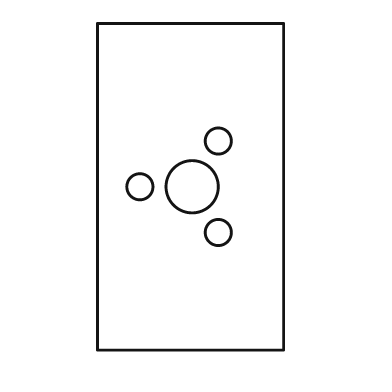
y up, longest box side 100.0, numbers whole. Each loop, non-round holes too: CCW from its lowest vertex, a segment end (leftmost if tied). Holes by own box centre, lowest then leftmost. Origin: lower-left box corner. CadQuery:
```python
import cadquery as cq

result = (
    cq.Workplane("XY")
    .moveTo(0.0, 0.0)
    .lineTo(57.0, 0.0)
    .lineTo(57.0, 100.0)
    .lineTo(0.0, 100.0)
    .close()
    .moveTo(37.0, 36.0)
    .circle(4.0)
    .moveTo(13.0, 50.0)
    .circle(4.0)
    .moveTo(29.0, 50.0)
    .circle(8.0)
    .moveTo(37.0, 64.0)
    .circle(4.0)
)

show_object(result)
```